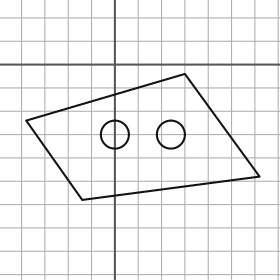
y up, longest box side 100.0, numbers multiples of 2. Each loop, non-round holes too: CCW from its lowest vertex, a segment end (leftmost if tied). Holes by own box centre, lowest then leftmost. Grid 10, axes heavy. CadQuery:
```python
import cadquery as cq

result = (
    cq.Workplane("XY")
    .moveTo(-14.0, -58.0)
    .lineTo(62.0, -48.0)
    .lineTo(30.0, -4.0)
    .lineTo(-38.0, -24.0)
    .close()
    .moveTo(0.0, -30.0)
    .circle(6.0)
    .moveTo(24.0, -30.0)
    .circle(6.0)
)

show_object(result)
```